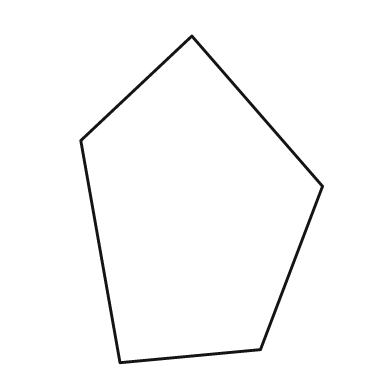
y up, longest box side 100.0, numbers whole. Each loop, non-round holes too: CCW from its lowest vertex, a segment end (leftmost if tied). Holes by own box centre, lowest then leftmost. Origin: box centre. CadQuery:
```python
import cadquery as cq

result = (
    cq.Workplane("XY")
    .moveTo(-25.0, -50.0)
    .lineTo(18.0, -46.0)
    .lineTo(37.0, 4.0)
    .lineTo(-3.0, 50.0)
    .lineTo(-37.0, 18.0)
    .close()
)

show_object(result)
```